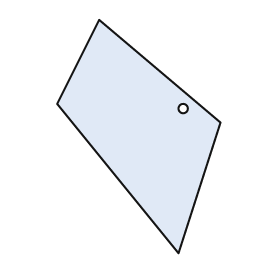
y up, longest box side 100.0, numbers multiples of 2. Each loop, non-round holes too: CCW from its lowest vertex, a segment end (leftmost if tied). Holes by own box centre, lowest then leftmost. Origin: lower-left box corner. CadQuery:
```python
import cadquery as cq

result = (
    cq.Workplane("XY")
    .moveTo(52.0, 0.0)
    .lineTo(70.0, 56.0)
    .lineTo(18.0, 100.0)
    .lineTo(0.0, 64.0)
    .close()
    .moveTo(54.0, 62.0)
    .circle(2.0)
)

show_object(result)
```